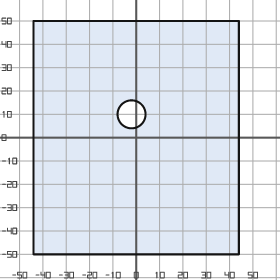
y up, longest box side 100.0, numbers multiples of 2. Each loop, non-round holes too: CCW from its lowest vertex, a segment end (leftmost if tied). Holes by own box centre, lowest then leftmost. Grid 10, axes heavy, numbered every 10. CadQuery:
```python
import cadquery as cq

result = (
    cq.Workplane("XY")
    .moveTo(-44.0, -50.0)
    .lineTo(44.0, -50.0)
    .lineTo(44.0, 50.0)
    .lineTo(-44.0, 50.0)
    .close()
    .moveTo(-2.0, 10.0)
    .circle(6.0)
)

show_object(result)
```